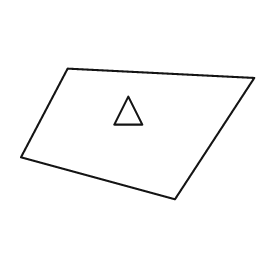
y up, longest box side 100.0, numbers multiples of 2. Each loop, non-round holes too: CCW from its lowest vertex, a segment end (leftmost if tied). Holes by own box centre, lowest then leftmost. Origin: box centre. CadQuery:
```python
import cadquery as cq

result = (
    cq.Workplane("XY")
    .moveTo(16.0, -28.0)
    .lineTo(50.0, 24.0)
    .lineTo(-30.0, 28.0)
    .lineTo(-50.0, -10.0)
    .close()
    .moveTo(-10.0, 4.0)
    .lineTo(2.0, 4.0)
    .lineTo(-4.0, 16.0)
    .close()
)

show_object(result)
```